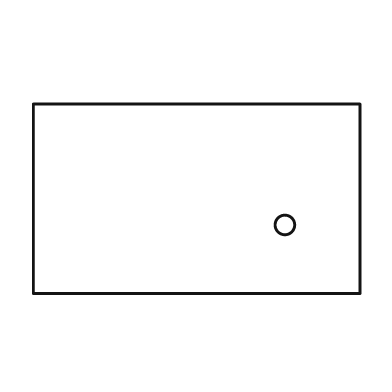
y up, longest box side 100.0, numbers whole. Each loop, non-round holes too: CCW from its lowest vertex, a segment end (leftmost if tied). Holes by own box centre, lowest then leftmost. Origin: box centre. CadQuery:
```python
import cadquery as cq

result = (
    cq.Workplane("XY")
    .moveTo(-50.0, -29.0)
    .lineTo(50.0, -29.0)
    .lineTo(50.0, 29.0)
    .lineTo(-50.0, 29.0)
    .close()
    .moveTo(27.0, -8.0)
    .circle(3.0)
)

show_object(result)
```